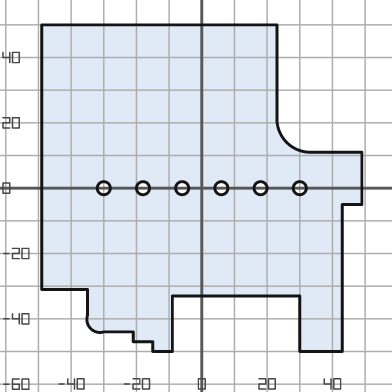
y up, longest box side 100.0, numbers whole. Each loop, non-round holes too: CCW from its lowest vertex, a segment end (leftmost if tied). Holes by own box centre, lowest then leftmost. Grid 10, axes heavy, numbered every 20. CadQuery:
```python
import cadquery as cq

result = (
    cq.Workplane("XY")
    .moveTo(-15.0, -50.0)
    .lineTo(-9.0, -50.0)
    .lineTo(-9.0, -33.0)
    .lineTo(30.0, -33.0)
    .lineTo(30.0, -50.0)
    .lineTo(43.0, -50.0)
    .lineTo(43.0, -5.0)
    .lineTo(49.0, -5.0)
    .lineTo(49.0, 11.0)
    .lineTo(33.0, 11.0)
    .threePointArc((26.0, 14.0), (23.0, 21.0))
    .lineTo(23.0, 50.0)
    .lineTo(-49.0, 50.0)
    .lineTo(-49.0, -31.0)
    .lineTo(-35.0, -31.0)
    .lineTo(-35.0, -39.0)
    .threePointArc((-34.0, -43.0), (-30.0, -44.0))
    .lineTo(-21.0, -44.0)
    .lineTo(-21.0, -47.0)
    .lineTo(-15.0, -47.0)
    .close()
    .moveTo(-30.0, 0.0)
    .circle(2.0)
    .moveTo(-18.0, 0.0)
    .circle(2.0)
    .moveTo(-6.0, 0.0)
    .circle(2.0)
    .moveTo(6.0, 0.0)
    .circle(2.0)
    .moveTo(18.0, 0.0)
    .circle(2.0)
    .moveTo(30.0, 0.0)
    .circle(2.0)
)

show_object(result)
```